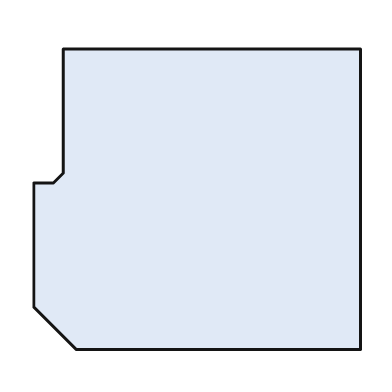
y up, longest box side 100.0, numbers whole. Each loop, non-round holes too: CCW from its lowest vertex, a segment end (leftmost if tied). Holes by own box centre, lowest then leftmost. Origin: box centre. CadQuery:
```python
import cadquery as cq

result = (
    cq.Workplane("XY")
    .moveTo(-37.0, -46.0)
    .lineTo(50.0, -46.0)
    .lineTo(50.0, 46.0)
    .lineTo(-41.0, 46.0)
    .lineTo(-41.0, 8.0)
    .lineTo(-44.0, 5.0)
    .lineTo(-50.0, 5.0)
    .lineTo(-50.0, -33.0)
    .close()
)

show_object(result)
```